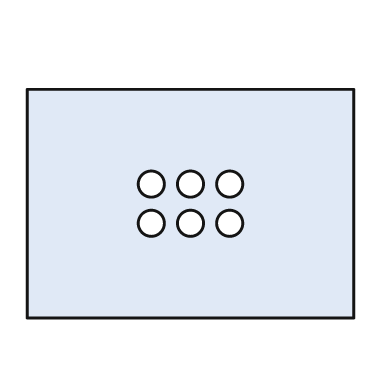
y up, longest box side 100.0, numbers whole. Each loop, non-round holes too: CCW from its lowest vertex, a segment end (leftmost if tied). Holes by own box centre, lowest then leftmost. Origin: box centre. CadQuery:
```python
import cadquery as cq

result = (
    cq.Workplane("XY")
    .moveTo(-50.0, -35.0)
    .lineTo(50.0, -35.0)
    .lineTo(50.0, 35.0)
    .lineTo(-50.0, 35.0)
    .close()
    .moveTo(-12.0, -6.0)
    .circle(4.0)
    .moveTo(0.0, -6.0)
    .circle(4.0)
    .moveTo(12.0, -6.0)
    .circle(4.0)
    .moveTo(-12.0, 6.0)
    .circle(4.0)
    .moveTo(0.0, 6.0)
    .circle(4.0)
    .moveTo(12.0, 6.0)
    .circle(4.0)
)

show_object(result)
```